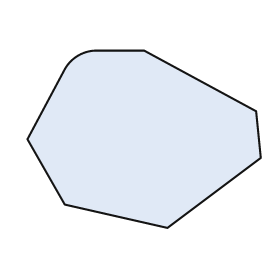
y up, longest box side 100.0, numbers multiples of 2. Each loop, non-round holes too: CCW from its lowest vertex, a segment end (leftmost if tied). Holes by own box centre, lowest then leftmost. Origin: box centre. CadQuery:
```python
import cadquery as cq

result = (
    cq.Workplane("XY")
    .moveTo(10.0, -38.0)
    .lineTo(50.0, -8.0)
    .lineTo(48.0, 12.0)
    .lineTo(0.0, 38.0)
    .lineTo(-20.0, 38.0)
    .threePointArc((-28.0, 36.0), (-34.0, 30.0))
    .lineTo(-50.0, 0.0)
    .lineTo(-34.0, -28.0)
    .close()
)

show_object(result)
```